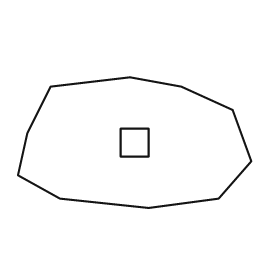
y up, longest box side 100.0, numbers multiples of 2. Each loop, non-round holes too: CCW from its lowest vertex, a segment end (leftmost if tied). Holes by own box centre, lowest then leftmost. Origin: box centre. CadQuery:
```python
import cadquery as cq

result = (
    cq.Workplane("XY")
    .moveTo(6.0, -28.0)
    .lineTo(36.0, -24.0)
    .lineTo(50.0, -8.0)
    .lineTo(42.0, 14.0)
    .lineTo(20.0, 24.0)
    .lineTo(-2.0, 28.0)
    .lineTo(-36.0, 24.0)
    .lineTo(-46.0, 4.0)
    .lineTo(-50.0, -14.0)
    .lineTo(-32.0, -24.0)
    .close()
    .moveTo(-6.0, -6.0)
    .lineTo(6.0, -6.0)
    .lineTo(6.0, 6.0)
    .lineTo(-6.0, 6.0)
    .close()
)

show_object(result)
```